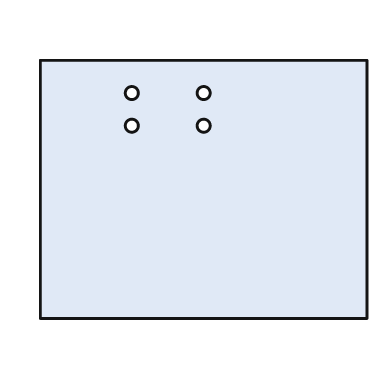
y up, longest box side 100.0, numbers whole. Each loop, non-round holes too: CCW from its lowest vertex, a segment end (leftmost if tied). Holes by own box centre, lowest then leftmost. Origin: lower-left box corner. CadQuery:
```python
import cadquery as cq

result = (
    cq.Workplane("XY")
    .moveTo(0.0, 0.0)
    .lineTo(100.0, 0.0)
    .lineTo(100.0, 79.0)
    .lineTo(0.0, 79.0)
    .close()
    .moveTo(28.0, 59.0)
    .circle(2.0)
    .moveTo(50.0, 59.0)
    .circle(2.0)
    .moveTo(28.0, 69.0)
    .circle(2.0)
    .moveTo(50.0, 69.0)
    .circle(2.0)
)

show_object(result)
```